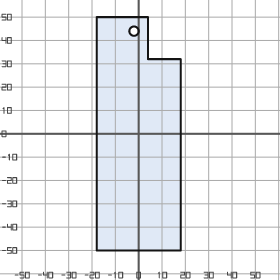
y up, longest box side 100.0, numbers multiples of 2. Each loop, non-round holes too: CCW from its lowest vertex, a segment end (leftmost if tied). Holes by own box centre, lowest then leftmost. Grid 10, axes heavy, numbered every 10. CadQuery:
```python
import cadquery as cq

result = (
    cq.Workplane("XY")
    .moveTo(-18.0, -50.0)
    .lineTo(18.0, -50.0)
    .lineTo(18.0, 32.0)
    .lineTo(4.0, 32.0)
    .lineTo(4.0, 50.0)
    .lineTo(-18.0, 50.0)
    .close()
    .moveTo(-2.0, 44.0)
    .circle(2.0)
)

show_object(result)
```